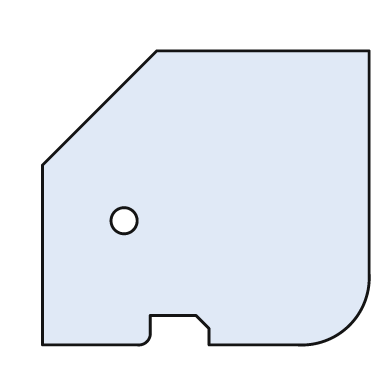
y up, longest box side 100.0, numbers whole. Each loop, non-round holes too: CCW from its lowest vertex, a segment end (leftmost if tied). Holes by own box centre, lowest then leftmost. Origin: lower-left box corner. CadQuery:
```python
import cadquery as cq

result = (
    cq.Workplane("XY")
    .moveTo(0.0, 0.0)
    .lineTo(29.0, 0.0)
    .threePointArc((32.0, 1.0), (33.0, 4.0))
    .lineTo(33.0, 9.0)
    .lineTo(47.0, 9.0)
    .lineTo(51.0, 5.0)
    .lineTo(51.0, 0.0)
    .lineTo(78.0, 0.0)
    .threePointArc((94.0, 6.0), (100.0, 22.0))
    .lineTo(100.0, 90.0)
    .lineTo(35.0, 90.0)
    .lineTo(0.0, 55.0)
    .close()
    .moveTo(25.0, 38.0)
    .circle(4.0)
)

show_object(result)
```